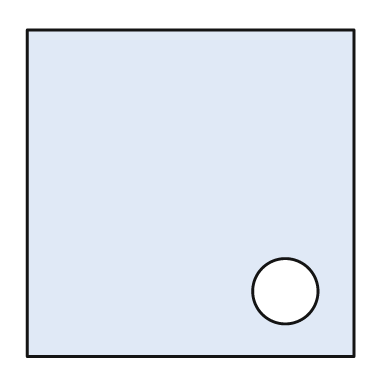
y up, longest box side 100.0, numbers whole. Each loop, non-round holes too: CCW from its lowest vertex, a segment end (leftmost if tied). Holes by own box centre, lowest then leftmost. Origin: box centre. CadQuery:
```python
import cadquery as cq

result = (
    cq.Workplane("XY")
    .moveTo(-50.0, -50.0)
    .lineTo(50.0, -50.0)
    .lineTo(50.0, 50.0)
    .lineTo(-50.0, 50.0)
    .close()
    .moveTo(29.0, -30.0)
    .circle(10.0)
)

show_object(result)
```